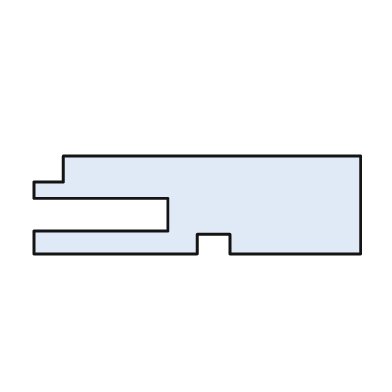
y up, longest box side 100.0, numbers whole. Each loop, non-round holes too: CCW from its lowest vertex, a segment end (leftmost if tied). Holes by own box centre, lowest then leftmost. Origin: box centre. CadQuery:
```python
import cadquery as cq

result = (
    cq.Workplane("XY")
    .moveTo(-50.0, -15.0)
    .lineTo(0.0, -15.0)
    .lineTo(0.0, -9.0)
    .lineTo(10.0, -9.0)
    .lineTo(10.0, -15.0)
    .lineTo(50.0, -15.0)
    .lineTo(50.0, 15.0)
    .lineTo(-41.0, 15.0)
    .lineTo(-41.0, 7.0)
    .lineTo(-50.0, 7.0)
    .lineTo(-50.0, 2.0)
    .lineTo(-9.0, 2.0)
    .lineTo(-9.0, -8.0)
    .lineTo(-50.0, -8.0)
    .close()
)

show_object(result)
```